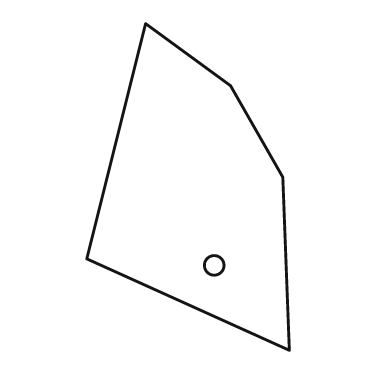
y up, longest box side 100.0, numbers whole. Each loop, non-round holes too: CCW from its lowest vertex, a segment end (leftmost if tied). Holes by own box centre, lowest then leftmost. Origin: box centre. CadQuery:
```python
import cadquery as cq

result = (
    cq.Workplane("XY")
    .moveTo(31.0, -50.0)
    .lineTo(29.0, 3.0)
    .lineTo(13.0, 31.0)
    .lineTo(-13.0, 50.0)
    .lineTo(-31.0, -22.0)
    .close()
    .moveTo(8.0, -24.0)
    .circle(3.0)
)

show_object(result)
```